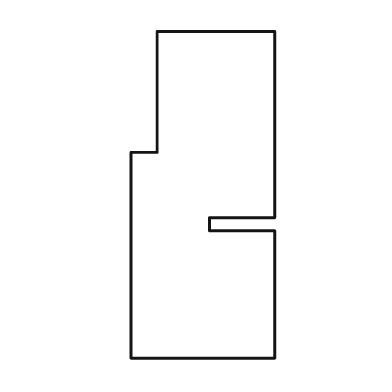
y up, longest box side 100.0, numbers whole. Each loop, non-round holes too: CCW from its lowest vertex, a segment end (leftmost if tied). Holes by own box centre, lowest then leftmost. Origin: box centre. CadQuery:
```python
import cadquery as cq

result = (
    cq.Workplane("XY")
    .moveTo(-22.0, -50.0)
    .lineTo(22.0, -50.0)
    .lineTo(22.0, -11.0)
    .lineTo(2.0, -11.0)
    .lineTo(2.0, -7.0)
    .lineTo(22.0, -7.0)
    .lineTo(22.0, 50.0)
    .lineTo(-14.0, 50.0)
    .lineTo(-14.0, 13.0)
    .lineTo(-22.0, 13.0)
    .close()
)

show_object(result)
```